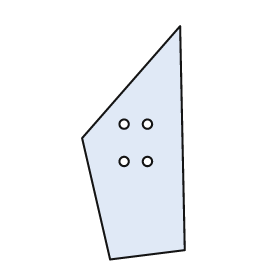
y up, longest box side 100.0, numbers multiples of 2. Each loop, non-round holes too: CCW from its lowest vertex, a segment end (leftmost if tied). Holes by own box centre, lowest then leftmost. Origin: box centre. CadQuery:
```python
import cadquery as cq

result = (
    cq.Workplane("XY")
    .moveTo(-10.0, -50.0)
    .lineTo(22.0, -46.0)
    .lineTo(20.0, 50.0)
    .lineTo(-22.0, 2.0)
    .close()
    .moveTo(-4.0, -8.0)
    .circle(2.0)
    .moveTo(6.0, -8.0)
    .circle(2.0)
    .moveTo(-4.0, 8.0)
    .circle(2.0)
    .moveTo(6.0, 8.0)
    .circle(2.0)
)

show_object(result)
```